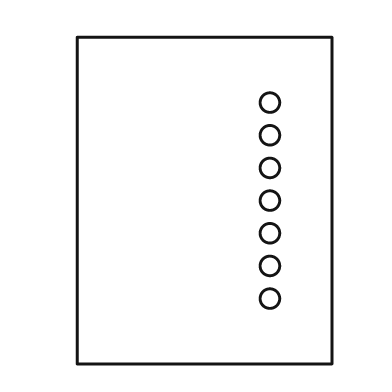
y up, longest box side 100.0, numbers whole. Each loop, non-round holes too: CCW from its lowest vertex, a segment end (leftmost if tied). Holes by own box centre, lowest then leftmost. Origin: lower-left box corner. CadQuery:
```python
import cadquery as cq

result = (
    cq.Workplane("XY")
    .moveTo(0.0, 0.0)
    .lineTo(78.0, 0.0)
    .lineTo(78.0, 100.0)
    .lineTo(0.0, 100.0)
    .close()
    .moveTo(59.0, 20.0)
    .circle(3.0)
    .moveTo(59.0, 30.0)
    .circle(3.0)
    .moveTo(59.0, 40.0)
    .circle(3.0)
    .moveTo(59.0, 50.0)
    .circle(3.0)
    .moveTo(59.0, 60.0)
    .circle(3.0)
    .moveTo(59.0, 70.0)
    .circle(3.0)
    .moveTo(59.0, 80.0)
    .circle(3.0)
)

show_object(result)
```